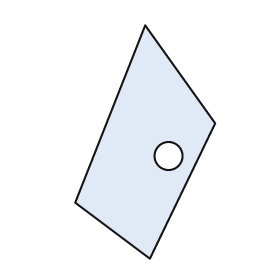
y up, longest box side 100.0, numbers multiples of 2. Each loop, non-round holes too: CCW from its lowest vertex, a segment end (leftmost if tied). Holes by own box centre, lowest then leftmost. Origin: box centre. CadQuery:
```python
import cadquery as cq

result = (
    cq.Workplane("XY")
    .moveTo(2.0, -50.0)
    .lineTo(30.0, 8.0)
    .lineTo(0.0, 50.0)
    .lineTo(-30.0, -26.0)
    .close()
    .moveTo(10.0, -6.0)
    .circle(6.0)
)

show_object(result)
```